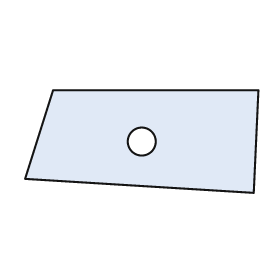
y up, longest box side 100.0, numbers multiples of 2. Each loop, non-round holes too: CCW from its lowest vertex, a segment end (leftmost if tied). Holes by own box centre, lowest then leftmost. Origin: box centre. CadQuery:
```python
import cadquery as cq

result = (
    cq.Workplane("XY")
    .moveTo(48.0, -22.0)
    .lineTo(50.0, 22.0)
    .lineTo(-38.0, 22.0)
    .lineTo(-50.0, -16.0)
    .close()
    .moveTo(0.0, 0.0)
    .circle(6.0)
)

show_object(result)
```